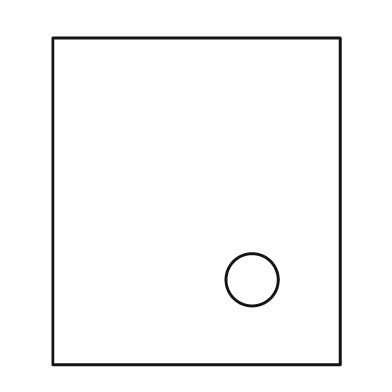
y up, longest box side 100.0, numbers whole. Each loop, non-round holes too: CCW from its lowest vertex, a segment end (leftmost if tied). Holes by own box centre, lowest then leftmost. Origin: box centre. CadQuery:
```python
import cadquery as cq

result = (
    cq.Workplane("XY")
    .moveTo(-44.0, -50.0)
    .lineTo(44.0, -50.0)
    .lineTo(44.0, 50.0)
    .lineTo(-44.0, 50.0)
    .close()
    .moveTo(17.0, -24.0)
    .circle(8.0)
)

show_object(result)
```